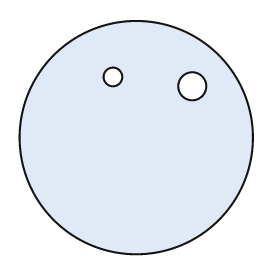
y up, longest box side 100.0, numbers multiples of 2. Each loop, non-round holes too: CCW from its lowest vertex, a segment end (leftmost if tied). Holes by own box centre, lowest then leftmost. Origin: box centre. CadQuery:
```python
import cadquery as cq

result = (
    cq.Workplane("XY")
    .moveTo(0.0, 0.0)
    .circle(50.0)
    .moveTo(24.0, 22.0)
    .circle(6.0)
    .moveTo(-10.0, 26.0)
    .circle(4.0)
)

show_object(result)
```